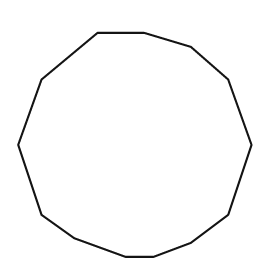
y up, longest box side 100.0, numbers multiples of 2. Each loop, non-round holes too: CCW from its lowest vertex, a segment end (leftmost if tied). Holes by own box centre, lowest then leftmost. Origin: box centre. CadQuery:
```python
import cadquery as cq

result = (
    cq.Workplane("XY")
    .moveTo(-4.0, -48.0)
    .lineTo(8.0, -48.0)
    .lineTo(24.0, -42.0)
    .lineTo(40.0, -30.0)
    .lineTo(50.0, 0.0)
    .lineTo(40.0, 28.0)
    .lineTo(24.0, 42.0)
    .lineTo(4.0, 48.0)
    .lineTo(-16.0, 48.0)
    .lineTo(-40.0, 28.0)
    .lineTo(-50.0, 0.0)
    .lineTo(-40.0, -30.0)
    .lineTo(-26.0, -40.0)
    .close()
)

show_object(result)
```